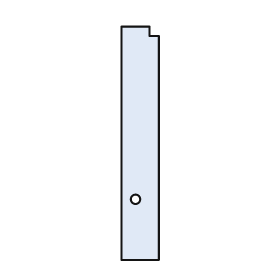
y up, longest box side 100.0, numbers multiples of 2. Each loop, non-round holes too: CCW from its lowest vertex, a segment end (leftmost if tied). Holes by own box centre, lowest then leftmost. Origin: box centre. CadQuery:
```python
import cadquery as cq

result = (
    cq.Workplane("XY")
    .moveTo(-8.0, -50.0)
    .lineTo(8.0, -50.0)
    .lineTo(8.0, 46.0)
    .lineTo(4.0, 46.0)
    .lineTo(4.0, 50.0)
    .lineTo(-8.0, 50.0)
    .close()
    .moveTo(-2.0, -24.0)
    .circle(2.0)
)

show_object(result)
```